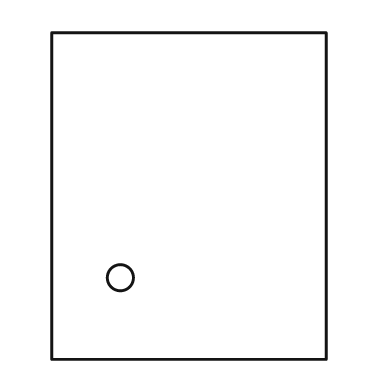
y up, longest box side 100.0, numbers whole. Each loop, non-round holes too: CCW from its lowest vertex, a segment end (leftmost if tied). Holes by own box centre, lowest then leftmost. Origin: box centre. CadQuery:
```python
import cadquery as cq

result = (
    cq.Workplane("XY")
    .moveTo(-42.0, -50.0)
    .lineTo(42.0, -50.0)
    .lineTo(42.0, 50.0)
    .lineTo(-42.0, 50.0)
    .close()
    .moveTo(-21.0, -25.0)
    .circle(4.0)
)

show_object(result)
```